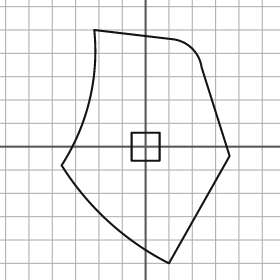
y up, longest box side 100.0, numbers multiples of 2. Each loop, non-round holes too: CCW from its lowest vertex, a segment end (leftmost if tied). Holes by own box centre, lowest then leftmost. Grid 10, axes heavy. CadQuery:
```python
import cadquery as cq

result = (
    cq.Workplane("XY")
    .moveTo(10.0, -50.0)
    .lineTo(36.0, -4.0)
    .lineTo(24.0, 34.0)
    .threePointArc((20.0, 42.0), (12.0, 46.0))
    .lineTo(-22.0, 50.0)
    .threePointArc((-24.0, 20.0), (-36.0, -8.0))
    .threePointArc((-16.0, -32.0), (10.0, -50.0))
    .close()
    .moveTo(-6.0, -6.0)
    .lineTo(6.0, -6.0)
    .lineTo(6.0, 6.0)
    .lineTo(-6.0, 6.0)
    .close()
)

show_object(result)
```